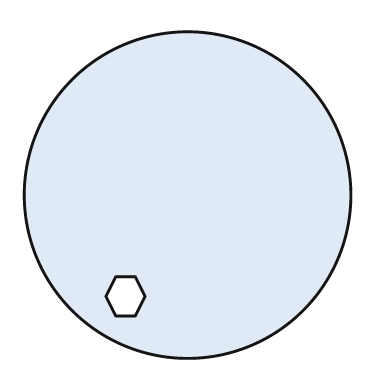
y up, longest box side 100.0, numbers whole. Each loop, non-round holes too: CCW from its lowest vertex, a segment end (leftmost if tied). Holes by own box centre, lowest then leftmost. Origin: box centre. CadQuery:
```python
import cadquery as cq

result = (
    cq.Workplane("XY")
    .moveTo(0.0, 0.0)
    .circle(50.0)
    .moveTo(-22.0, -37.0)
    .lineTo(-16.0, -37.0)
    .lineTo(-13.0, -31.0)
    .lineTo(-16.0, -25.0)
    .lineTo(-22.0, -25.0)
    .lineTo(-25.0, -31.0)
    .close()
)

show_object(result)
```